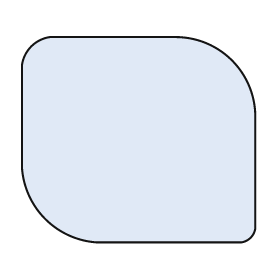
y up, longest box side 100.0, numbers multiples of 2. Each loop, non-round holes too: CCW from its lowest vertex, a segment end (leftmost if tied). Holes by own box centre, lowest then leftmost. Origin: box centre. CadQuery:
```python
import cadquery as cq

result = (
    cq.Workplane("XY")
    .moveTo(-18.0, -44.0)
    .lineTo(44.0, -44.0)
    .threePointArc((48.0, -42.0), (50.0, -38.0))
    .lineTo(50.0, 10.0)
    .threePointArc((40.0, 34.0), (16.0, 44.0))
    .lineTo(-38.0, 44.0)
    .threePointArc((-46.0, 40.0), (-50.0, 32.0))
    .lineTo(-50.0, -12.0)
    .threePointArc((-40.0, -34.0), (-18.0, -44.0))
    .close()
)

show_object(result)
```